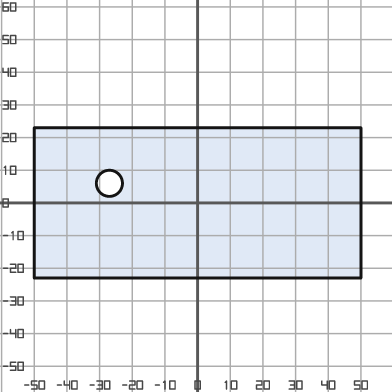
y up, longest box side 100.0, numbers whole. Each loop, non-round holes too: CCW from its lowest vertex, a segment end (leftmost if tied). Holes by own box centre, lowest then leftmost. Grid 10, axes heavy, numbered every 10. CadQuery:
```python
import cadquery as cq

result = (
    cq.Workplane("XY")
    .moveTo(-50.0, -23.0)
    .lineTo(50.0, -23.0)
    .lineTo(50.0, 23.0)
    .lineTo(-50.0, 23.0)
    .close()
    .moveTo(-27.0, 6.0)
    .circle(4.0)
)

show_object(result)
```